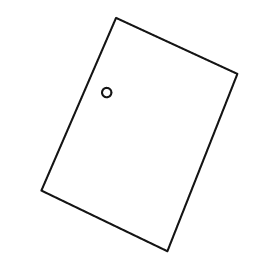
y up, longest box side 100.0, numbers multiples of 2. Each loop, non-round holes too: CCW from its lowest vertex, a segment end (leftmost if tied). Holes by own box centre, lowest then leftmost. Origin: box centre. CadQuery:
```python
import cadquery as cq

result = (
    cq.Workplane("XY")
    .moveTo(12.0, -50.0)
    .lineTo(42.0, 26.0)
    .lineTo(-10.0, 50.0)
    .lineTo(-42.0, -24.0)
    .close()
    .moveTo(-14.0, 18.0)
    .circle(2.0)
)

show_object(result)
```